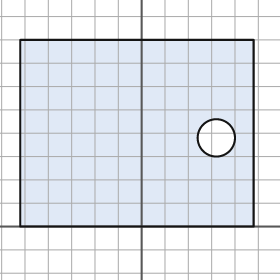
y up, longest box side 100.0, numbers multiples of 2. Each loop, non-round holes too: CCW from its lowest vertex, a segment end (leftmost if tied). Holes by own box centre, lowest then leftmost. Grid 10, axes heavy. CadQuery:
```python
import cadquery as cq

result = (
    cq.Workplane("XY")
    .moveTo(-52.0, 0.0)
    .lineTo(48.0, 0.0)
    .lineTo(48.0, 80.0)
    .lineTo(-52.0, 80.0)
    .close()
    .moveTo(32.0, 38.0)
    .circle(8.0)
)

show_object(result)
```